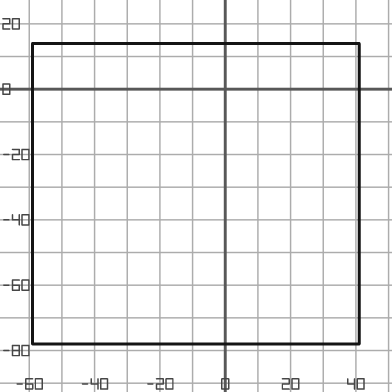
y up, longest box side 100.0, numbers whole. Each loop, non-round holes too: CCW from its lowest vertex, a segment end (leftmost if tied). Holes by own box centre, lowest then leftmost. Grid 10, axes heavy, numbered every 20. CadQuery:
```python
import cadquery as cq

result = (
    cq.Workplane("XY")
    .moveTo(-59.0, -78.0)
    .lineTo(41.0, -78.0)
    .lineTo(41.0, 14.0)
    .lineTo(-59.0, 14.0)
    .close()
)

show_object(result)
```